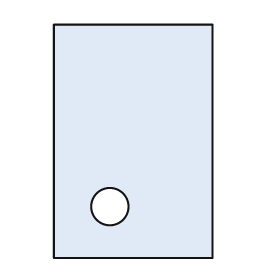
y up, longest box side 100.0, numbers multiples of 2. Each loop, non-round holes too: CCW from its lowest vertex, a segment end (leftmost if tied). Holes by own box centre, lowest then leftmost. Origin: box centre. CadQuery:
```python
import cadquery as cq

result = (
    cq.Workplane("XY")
    .moveTo(-34.0, -50.0)
    .lineTo(34.0, -50.0)
    .lineTo(34.0, 50.0)
    .lineTo(-34.0, 50.0)
    .close()
    .moveTo(-10.0, -28.0)
    .circle(8.0)
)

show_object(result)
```